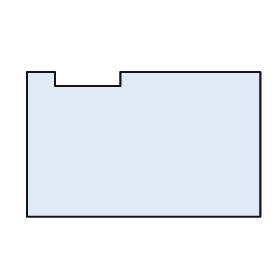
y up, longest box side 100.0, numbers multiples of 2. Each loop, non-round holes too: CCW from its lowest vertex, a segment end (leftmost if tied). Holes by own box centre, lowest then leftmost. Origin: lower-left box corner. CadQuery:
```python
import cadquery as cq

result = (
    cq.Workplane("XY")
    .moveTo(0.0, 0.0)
    .lineTo(100.0, 0.0)
    .lineTo(100.0, 62.0)
    .lineTo(40.0, 62.0)
    .lineTo(40.0, 56.0)
    .lineTo(12.0, 56.0)
    .lineTo(12.0, 62.0)
    .lineTo(0.0, 62.0)
    .close()
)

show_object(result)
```